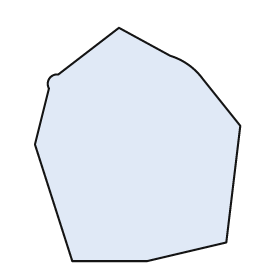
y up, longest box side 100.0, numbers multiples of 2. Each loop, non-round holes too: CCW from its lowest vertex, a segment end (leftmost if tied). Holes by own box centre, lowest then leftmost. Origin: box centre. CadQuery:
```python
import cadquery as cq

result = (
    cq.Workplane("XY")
    .moveTo(-28.0, -50.0)
    .lineTo(4.0, -50.0)
    .lineTo(38.0, -42.0)
    .lineTo(44.0, 8.0)
    .lineTo(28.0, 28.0)
    .threePointArc((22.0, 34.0), (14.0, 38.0))
    .lineTo(-8.0, 50.0)
    .lineTo(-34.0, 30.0)
    .threePointArc((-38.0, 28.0), (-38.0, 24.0))
    .lineTo(-44.0, 0.0)
    .close()
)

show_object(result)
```